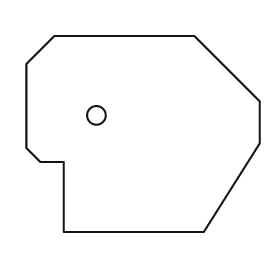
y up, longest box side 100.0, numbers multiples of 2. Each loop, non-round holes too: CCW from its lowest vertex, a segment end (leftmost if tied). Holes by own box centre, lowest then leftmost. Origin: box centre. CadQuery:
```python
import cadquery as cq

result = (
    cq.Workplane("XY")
    .moveTo(-34.0, -42.0)
    .lineTo(26.0, -42.0)
    .lineTo(50.0, -4.0)
    .lineTo(50.0, 14.0)
    .lineTo(22.0, 42.0)
    .lineTo(-38.0, 42.0)
    .lineTo(-50.0, 30.0)
    .lineTo(-50.0, -6.0)
    .lineTo(-44.0, -12.0)
    .lineTo(-34.0, -12.0)
    .close()
    .moveTo(-20.0, 8.0)
    .circle(4.0)
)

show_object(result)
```